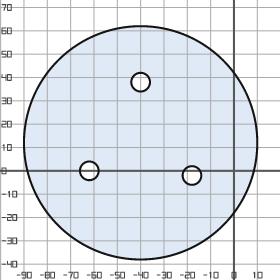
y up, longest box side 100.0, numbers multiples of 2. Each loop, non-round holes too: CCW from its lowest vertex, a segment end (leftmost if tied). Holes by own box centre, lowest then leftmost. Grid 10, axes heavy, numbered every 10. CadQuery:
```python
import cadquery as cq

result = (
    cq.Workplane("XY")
    .moveTo(-40.0, 12.0)
    .circle(50.0)
    .moveTo(-18.0, -2.0)
    .circle(4.0)
    .moveTo(-62.0, 0.0)
    .circle(4.0)
    .moveTo(-40.0, 38.0)
    .circle(4.0)
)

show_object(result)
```